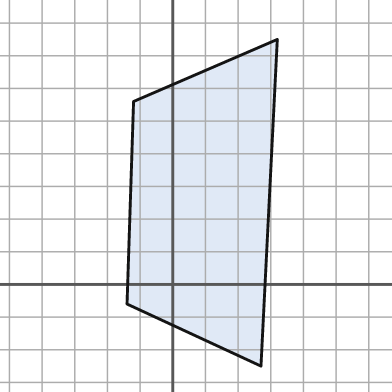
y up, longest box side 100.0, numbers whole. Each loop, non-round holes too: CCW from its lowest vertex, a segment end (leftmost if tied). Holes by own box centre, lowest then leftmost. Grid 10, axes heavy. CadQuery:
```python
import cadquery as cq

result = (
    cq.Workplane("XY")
    .moveTo(27.0, -25.0)
    .lineTo(32.0, 75.0)
    .lineTo(-12.0, 56.0)
    .lineTo(-14.0, -6.0)
    .close()
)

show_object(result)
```